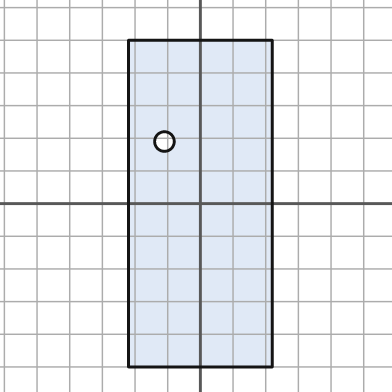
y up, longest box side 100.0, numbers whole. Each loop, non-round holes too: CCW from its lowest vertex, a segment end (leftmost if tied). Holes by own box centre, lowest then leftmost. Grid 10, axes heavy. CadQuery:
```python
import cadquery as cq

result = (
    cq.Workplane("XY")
    .moveTo(-22.0, -50.0)
    .lineTo(22.0, -50.0)
    .lineTo(22.0, 50.0)
    .lineTo(-22.0, 50.0)
    .close()
    .moveTo(-11.0, 19.0)
    .circle(3.0)
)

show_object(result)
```